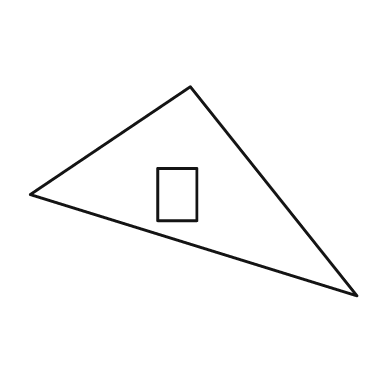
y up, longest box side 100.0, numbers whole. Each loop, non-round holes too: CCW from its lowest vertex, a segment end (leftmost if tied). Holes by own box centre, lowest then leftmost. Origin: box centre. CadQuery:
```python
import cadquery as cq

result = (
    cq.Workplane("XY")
    .moveTo(50.0, -32.0)
    .lineTo(-1.0, 32.0)
    .lineTo(-50.0, -1.0)
    .close()
    .moveTo(-11.0, -9.0)
    .lineTo(1.0, -9.0)
    .lineTo(1.0, 7.0)
    .lineTo(-11.0, 7.0)
    .close()
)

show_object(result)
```